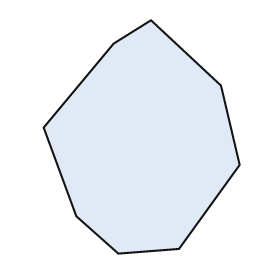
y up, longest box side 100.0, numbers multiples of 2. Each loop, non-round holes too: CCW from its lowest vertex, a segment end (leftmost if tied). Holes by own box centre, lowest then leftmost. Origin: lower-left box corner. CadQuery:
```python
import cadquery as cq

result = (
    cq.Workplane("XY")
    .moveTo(32.0, 0.0)
    .lineTo(58.0, 2.0)
    .lineTo(84.0, 38.0)
    .lineTo(76.0, 72.0)
    .lineTo(46.0, 100.0)
    .lineTo(30.0, 90.0)
    .lineTo(0.0, 54.0)
    .lineTo(14.0, 16.0)
    .close()
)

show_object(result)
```